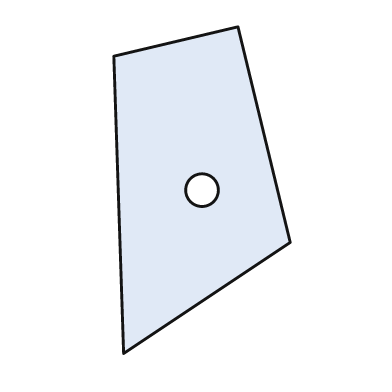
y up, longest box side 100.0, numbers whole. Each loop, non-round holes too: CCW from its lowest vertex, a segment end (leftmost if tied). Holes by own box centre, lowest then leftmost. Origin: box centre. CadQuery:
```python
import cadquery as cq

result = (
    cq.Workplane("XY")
    .moveTo(-24.0, -50.0)
    .lineTo(27.0, -16.0)
    .lineTo(11.0, 50.0)
    .lineTo(-27.0, 41.0)
    .close()
    .moveTo(0.0, 0.0)
    .circle(5.0)
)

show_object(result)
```